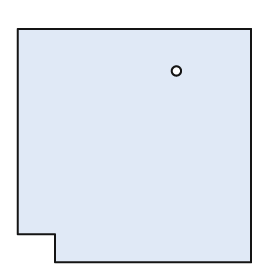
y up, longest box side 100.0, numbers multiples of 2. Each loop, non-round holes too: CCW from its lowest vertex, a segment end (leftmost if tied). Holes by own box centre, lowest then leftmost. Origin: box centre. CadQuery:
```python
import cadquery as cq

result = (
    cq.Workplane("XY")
    .moveTo(-34.0, -50.0)
    .lineTo(50.0, -50.0)
    .lineTo(50.0, 50.0)
    .lineTo(-50.0, 50.0)
    .lineTo(-50.0, -38.0)
    .lineTo(-34.0, -38.0)
    .close()
    .moveTo(18.0, 32.0)
    .circle(2.0)
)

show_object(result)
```